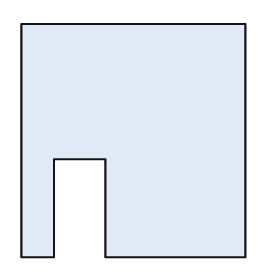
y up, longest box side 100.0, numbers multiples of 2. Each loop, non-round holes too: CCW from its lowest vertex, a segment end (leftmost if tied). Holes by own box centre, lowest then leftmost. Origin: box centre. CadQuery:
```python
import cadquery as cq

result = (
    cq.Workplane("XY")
    .moveTo(-48.0, -50.0)
    .lineTo(-34.0, -50.0)
    .lineTo(-34.0, -8.0)
    .lineTo(-12.0, -8.0)
    .lineTo(-12.0, -50.0)
    .lineTo(48.0, -50.0)
    .lineTo(48.0, 50.0)
    .lineTo(-48.0, 50.0)
    .close()
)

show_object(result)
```